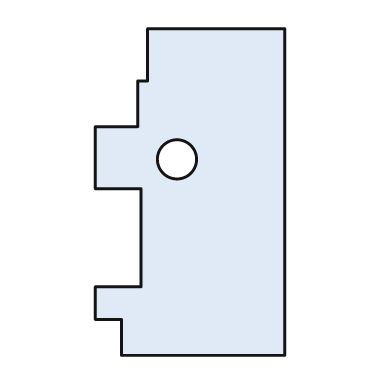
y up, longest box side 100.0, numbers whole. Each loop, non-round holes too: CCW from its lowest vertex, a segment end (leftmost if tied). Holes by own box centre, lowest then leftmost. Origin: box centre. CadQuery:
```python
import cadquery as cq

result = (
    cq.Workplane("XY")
    .moveTo(-21.0, -50.0)
    .lineTo(29.0, -50.0)
    .lineTo(29.0, 50.0)
    .lineTo(-13.0, 50.0)
    .lineTo(-13.0, 34.0)
    .lineTo(-16.0, 34.0)
    .lineTo(-16.0, 20.0)
    .lineTo(-29.0, 20.0)
    .lineTo(-29.0, 1.0)
    .lineTo(-15.0, 1.0)
    .lineTo(-15.0, -29.0)
    .lineTo(-29.0, -29.0)
    .lineTo(-29.0, -39.0)
    .lineTo(-21.0, -39.0)
    .close()
    .moveTo(-4.0, 10.0)
    .circle(6.0)
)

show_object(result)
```